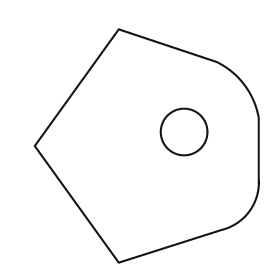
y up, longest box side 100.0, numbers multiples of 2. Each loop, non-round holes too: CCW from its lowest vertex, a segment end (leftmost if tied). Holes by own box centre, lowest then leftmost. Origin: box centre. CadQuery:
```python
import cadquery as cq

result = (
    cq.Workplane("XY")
    .moveTo(-12.0, -50.0)
    .lineTo(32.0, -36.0)
    .threePointArc((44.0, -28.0), (48.0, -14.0))
    .lineTo(48.0, 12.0)
    .threePointArc((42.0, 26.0), (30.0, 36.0))
    .lineTo(-12.0, 50.0)
    .lineTo(-48.0, 0.0)
    .close()
    .moveTo(16.0, 6.0)
    .circle(10.0)
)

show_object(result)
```